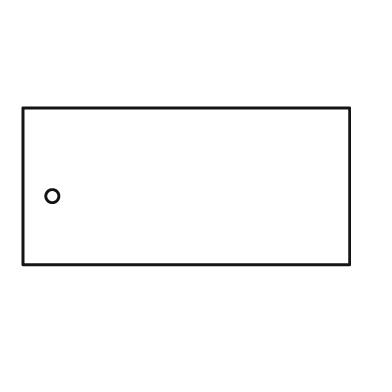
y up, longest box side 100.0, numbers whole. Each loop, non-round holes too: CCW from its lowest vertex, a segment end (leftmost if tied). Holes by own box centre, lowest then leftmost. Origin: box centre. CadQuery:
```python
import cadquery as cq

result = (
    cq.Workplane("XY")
    .moveTo(-50.0, -24.0)
    .lineTo(50.0, -24.0)
    .lineTo(50.0, 24.0)
    .lineTo(-50.0, 24.0)
    .close()
    .moveTo(-41.0, -3.0)
    .circle(2.0)
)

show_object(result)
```